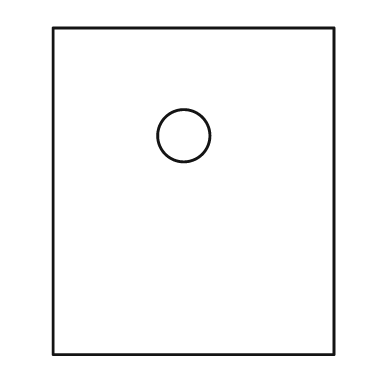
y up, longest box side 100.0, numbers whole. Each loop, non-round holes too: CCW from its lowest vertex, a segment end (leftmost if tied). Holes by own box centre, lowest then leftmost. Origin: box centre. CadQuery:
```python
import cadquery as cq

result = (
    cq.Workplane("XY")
    .moveTo(-43.0, -50.0)
    .lineTo(43.0, -50.0)
    .lineTo(43.0, 50.0)
    .lineTo(-43.0, 50.0)
    .close()
    .moveTo(-3.0, 17.0)
    .circle(8.0)
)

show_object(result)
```